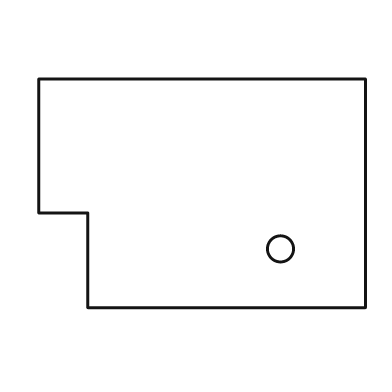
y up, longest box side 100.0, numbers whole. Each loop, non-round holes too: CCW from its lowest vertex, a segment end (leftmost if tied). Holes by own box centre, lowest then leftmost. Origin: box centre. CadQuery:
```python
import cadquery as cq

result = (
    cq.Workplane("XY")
    .moveTo(-35.0, -35.0)
    .lineTo(50.0, -35.0)
    .lineTo(50.0, 35.0)
    .lineTo(-50.0, 35.0)
    .lineTo(-50.0, -6.0)
    .lineTo(-35.0, -6.0)
    .close()
    .moveTo(24.0, -17.0)
    .circle(4.0)
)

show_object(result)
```